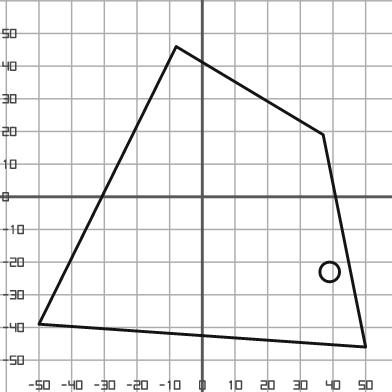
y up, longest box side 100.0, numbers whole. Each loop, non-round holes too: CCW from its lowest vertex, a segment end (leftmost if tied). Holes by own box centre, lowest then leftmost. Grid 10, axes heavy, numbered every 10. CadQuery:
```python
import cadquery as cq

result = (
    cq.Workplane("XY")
    .moveTo(50.0, -46.0)
    .lineTo(37.0, 19.0)
    .lineTo(-8.0, 46.0)
    .lineTo(-50.0, -39.0)
    .close()
    .moveTo(39.0, -23.0)
    .circle(3.0)
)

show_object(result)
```